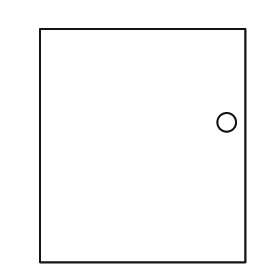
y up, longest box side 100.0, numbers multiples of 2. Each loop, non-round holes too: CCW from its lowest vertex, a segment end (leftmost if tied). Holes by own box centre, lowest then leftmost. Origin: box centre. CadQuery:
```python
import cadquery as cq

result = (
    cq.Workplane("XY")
    .moveTo(-44.0, -50.0)
    .lineTo(44.0, -50.0)
    .lineTo(44.0, 50.0)
    .lineTo(-44.0, 50.0)
    .close()
    .moveTo(36.0, 10.0)
    .circle(4.0)
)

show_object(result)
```